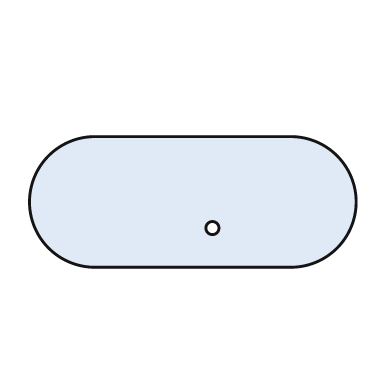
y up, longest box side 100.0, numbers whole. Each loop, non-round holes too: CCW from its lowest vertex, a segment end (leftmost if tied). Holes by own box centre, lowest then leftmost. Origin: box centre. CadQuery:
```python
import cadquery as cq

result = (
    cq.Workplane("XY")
    .moveTo(-30.0, -20.0)
    .lineTo(30.0, -20.0)
    .threePointArc((50.0, 0.0), (30.0, 20.0))
    .lineTo(-30.0, 20.0)
    .threePointArc((-50.0, 0.0), (-30.0, -20.0))
    .close()
    .moveTo(6.0, -8.0)
    .circle(2.0)
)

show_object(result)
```